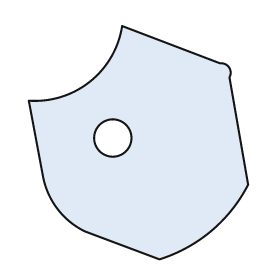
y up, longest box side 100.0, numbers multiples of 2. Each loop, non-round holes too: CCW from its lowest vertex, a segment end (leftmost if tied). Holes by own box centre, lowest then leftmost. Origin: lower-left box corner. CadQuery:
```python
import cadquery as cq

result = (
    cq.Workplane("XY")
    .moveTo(56.0, 0.0)
    .threePointArc((78.0, 12.0), (94.0, 32.0))
    .lineTo(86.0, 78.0)
    .threePointArc((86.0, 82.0), (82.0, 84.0))
    .lineTo(40.0, 100.0)
    .threePointArc((26.0, 76.0), (0.0, 68.0))
    .lineTo(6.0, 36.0)
    .threePointArc((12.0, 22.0), (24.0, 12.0))
    .close()
    .moveTo(36.0, 52.0)
    .circle(8.0)
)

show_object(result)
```